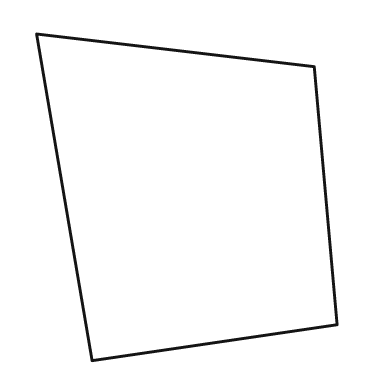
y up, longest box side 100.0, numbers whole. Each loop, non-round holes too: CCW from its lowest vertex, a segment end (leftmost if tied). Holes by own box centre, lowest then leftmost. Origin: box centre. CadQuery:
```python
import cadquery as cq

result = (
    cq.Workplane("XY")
    .moveTo(-29.0, -50.0)
    .lineTo(46.0, -39.0)
    .lineTo(39.0, 40.0)
    .lineTo(-46.0, 50.0)
    .close()
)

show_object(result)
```